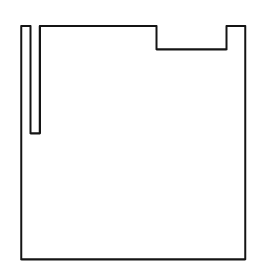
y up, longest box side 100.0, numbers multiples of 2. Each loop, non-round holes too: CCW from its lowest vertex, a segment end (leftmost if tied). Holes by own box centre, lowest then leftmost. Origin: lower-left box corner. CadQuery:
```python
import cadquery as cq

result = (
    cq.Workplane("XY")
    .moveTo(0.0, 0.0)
    .lineTo(96.0, 0.0)
    .lineTo(96.0, 100.0)
    .lineTo(88.0, 100.0)
    .lineTo(88.0, 90.0)
    .lineTo(58.0, 90.0)
    .lineTo(58.0, 100.0)
    .lineTo(8.0, 100.0)
    .lineTo(8.0, 54.0)
    .lineTo(4.0, 54.0)
    .lineTo(4.0, 100.0)
    .lineTo(0.0, 100.0)
    .close()
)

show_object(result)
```